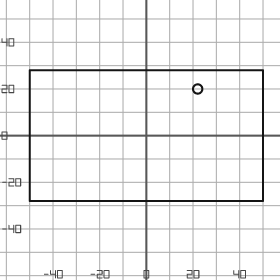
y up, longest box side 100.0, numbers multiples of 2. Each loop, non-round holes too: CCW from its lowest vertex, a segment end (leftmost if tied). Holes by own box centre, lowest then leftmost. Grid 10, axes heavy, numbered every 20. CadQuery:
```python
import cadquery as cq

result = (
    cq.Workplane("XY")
    .moveTo(-50.0, -28.0)
    .lineTo(50.0, -28.0)
    .lineTo(50.0, 28.0)
    .lineTo(-50.0, 28.0)
    .close()
    .moveTo(22.0, 20.0)
    .circle(2.0)
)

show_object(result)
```